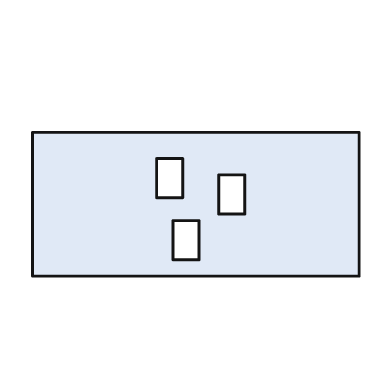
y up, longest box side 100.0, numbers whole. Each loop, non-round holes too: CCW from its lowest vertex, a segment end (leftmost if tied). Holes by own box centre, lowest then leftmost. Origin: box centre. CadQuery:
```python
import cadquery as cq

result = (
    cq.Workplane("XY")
    .moveTo(-50.0, -22.0)
    .lineTo(50.0, -22.0)
    .lineTo(50.0, 22.0)
    .lineTo(-50.0, 22.0)
    .close()
    .moveTo(-7.0, -17.0)
    .lineTo(1.0, -17.0)
    .lineTo(1.0, -5.0)
    .lineTo(-7.0, -5.0)
    .close()
    .moveTo(7.0, -3.0)
    .lineTo(15.0, -3.0)
    .lineTo(15.0, 9.0)
    .lineTo(7.0, 9.0)
    .close()
    .moveTo(-12.0, 2.0)
    .lineTo(-4.0, 2.0)
    .lineTo(-4.0, 14.0)
    .lineTo(-12.0, 14.0)
    .close()
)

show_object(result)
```